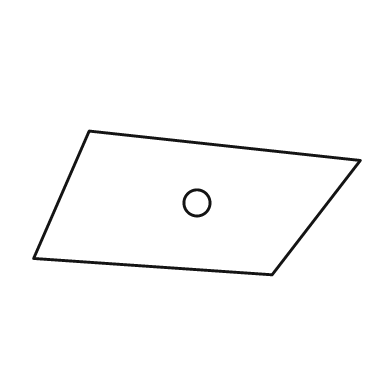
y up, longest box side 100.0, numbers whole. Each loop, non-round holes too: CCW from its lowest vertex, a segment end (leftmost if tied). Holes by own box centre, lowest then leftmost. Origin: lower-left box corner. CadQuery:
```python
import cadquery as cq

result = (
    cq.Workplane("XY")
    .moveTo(73.0, 0.0)
    .lineTo(100.0, 35.0)
    .lineTo(17.0, 44.0)
    .lineTo(0.0, 5.0)
    .close()
    .moveTo(50.0, 22.0)
    .circle(4.0)
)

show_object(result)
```